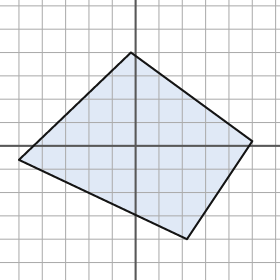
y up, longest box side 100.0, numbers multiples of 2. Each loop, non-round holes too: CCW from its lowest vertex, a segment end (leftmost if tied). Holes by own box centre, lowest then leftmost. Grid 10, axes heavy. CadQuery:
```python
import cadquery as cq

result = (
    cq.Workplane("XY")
    .moveTo(22.0, -40.0)
    .lineTo(50.0, 2.0)
    .lineTo(-2.0, 40.0)
    .lineTo(-50.0, -6.0)
    .close()
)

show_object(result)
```